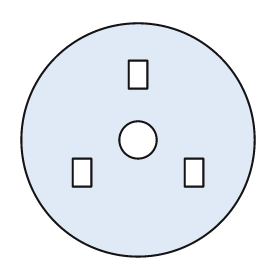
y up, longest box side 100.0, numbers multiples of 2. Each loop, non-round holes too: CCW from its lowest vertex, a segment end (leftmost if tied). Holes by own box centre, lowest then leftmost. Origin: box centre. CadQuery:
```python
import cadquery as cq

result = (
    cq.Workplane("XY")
    .moveTo(0.0, 0.0)
    .circle(50.0)
    .moveTo(-28.0, -20.0)
    .lineTo(-20.0, -20.0)
    .lineTo(-20.0, -8.0)
    .lineTo(-28.0, -8.0)
    .close()
    .moveTo(20.0, -20.0)
    .lineTo(28.0, -20.0)
    .lineTo(28.0, -8.0)
    .lineTo(20.0, -8.0)
    .close()
    .moveTo(0.0, 0.0)
    .circle(8.0)
    .moveTo(-4.0, 22.0)
    .lineTo(4.0, 22.0)
    .lineTo(4.0, 34.0)
    .lineTo(-4.0, 34.0)
    .close()
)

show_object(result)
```